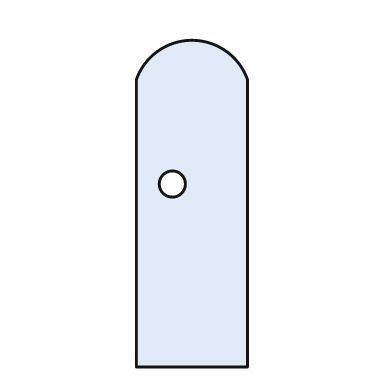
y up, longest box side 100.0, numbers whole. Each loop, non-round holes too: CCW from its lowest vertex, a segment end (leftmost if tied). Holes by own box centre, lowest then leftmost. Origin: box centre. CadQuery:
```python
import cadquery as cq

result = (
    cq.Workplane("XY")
    .moveTo(-17.0, -50.0)
    .lineTo(17.0, -50.0)
    .lineTo(17.0, 38.0)
    .threePointArc((0.0, 50.0), (-17.0, 38.0))
    .close()
    .moveTo(-6.0, 6.0)
    .circle(4.0)
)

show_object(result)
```